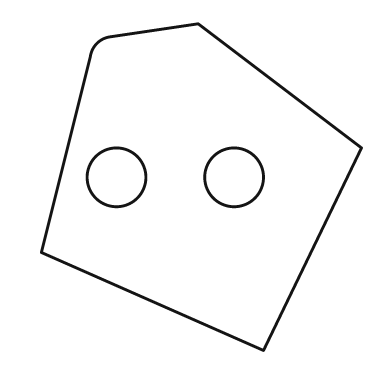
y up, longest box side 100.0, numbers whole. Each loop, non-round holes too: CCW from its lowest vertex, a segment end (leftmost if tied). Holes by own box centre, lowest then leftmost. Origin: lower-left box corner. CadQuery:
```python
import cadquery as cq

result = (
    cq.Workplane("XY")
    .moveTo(68.0, 0.0)
    .lineTo(98.0, 62.0)
    .lineTo(48.0, 100.0)
    .lineTo(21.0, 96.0)
    .threePointArc((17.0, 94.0), (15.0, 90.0))
    .lineTo(0.0, 30.0)
    .close()
    .moveTo(23.0, 53.0)
    .circle(9.0)
    .moveTo(59.0, 53.0)
    .circle(9.0)
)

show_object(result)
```